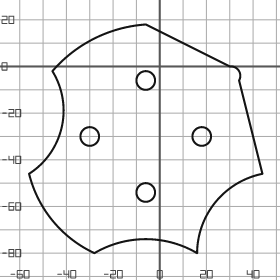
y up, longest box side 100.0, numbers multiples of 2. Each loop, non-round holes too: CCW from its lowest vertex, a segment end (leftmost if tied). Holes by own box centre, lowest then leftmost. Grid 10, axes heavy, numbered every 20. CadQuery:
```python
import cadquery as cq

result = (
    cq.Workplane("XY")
    .moveTo(-28.0, -80.0)
    .threePointArc((-6.0, -74.0), (16.0, -80.0))
    .threePointArc((24.0, -58.0), (44.0, -46.0))
    .lineTo(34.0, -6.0)
    .threePointArc((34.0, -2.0), (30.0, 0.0))
    .lineTo(-6.0, 18.0)
    .threePointArc((-28.0, 12.0), (-46.0, -2.0))
    .threePointArc((-42.0, -26.0), (-56.0, -46.0))
    .threePointArc((-46.0, -66.0), (-28.0, -80.0))
    .close()
    .moveTo(-6.0, -54.0)
    .circle(4.0)
    .moveTo(-30.0, -30.0)
    .circle(4.0)
    .moveTo(18.0, -30.0)
    .circle(4.0)
    .moveTo(-6.0, -6.0)
    .circle(4.0)
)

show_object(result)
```